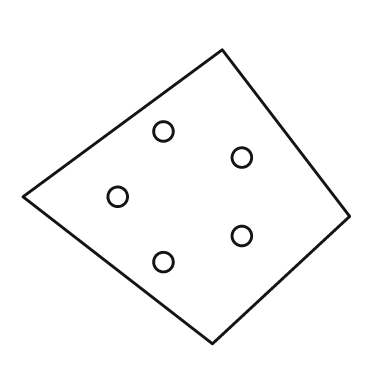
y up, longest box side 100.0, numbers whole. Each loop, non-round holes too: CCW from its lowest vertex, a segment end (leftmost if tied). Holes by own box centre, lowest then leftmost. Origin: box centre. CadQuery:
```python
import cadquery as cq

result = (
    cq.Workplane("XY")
    .moveTo(8.0, -45.0)
    .lineTo(50.0, -6.0)
    .lineTo(11.0, 45.0)
    .lineTo(-50.0, 0.0)
    .close()
    .moveTo(-7.0, -20.0)
    .circle(3.0)
    .moveTo(17.0, -12.0)
    .circle(3.0)
    .moveTo(-21.0, 0.0)
    .circle(3.0)
    .moveTo(17.0, 12.0)
    .circle(3.0)
    .moveTo(-7.0, 20.0)
    .circle(3.0)
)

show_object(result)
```